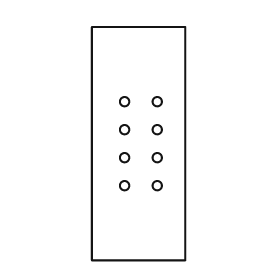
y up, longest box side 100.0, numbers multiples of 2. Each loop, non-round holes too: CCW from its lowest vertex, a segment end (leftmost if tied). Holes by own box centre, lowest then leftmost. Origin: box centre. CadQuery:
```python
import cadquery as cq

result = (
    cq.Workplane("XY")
    .moveTo(-20.0, -50.0)
    .lineTo(20.0, -50.0)
    .lineTo(20.0, 50.0)
    .lineTo(-20.0, 50.0)
    .close()
    .moveTo(-6.0, -18.0)
    .circle(2.0)
    .moveTo(8.0, -18.0)
    .circle(2.0)
    .moveTo(-6.0, -6.0)
    .circle(2.0)
    .moveTo(8.0, -6.0)
    .circle(2.0)
    .moveTo(-6.0, 6.0)
    .circle(2.0)
    .moveTo(8.0, 6.0)
    .circle(2.0)
    .moveTo(-6.0, 18.0)
    .circle(2.0)
    .moveTo(8.0, 18.0)
    .circle(2.0)
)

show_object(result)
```